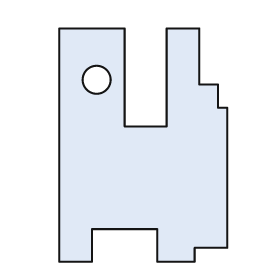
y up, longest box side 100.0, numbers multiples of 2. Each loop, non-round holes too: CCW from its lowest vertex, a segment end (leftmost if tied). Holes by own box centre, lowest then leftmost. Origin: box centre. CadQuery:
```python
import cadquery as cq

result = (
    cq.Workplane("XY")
    .moveTo(-36.0, -50.0)
    .lineTo(-22.0, -50.0)
    .lineTo(-22.0, -36.0)
    .lineTo(6.0, -36.0)
    .lineTo(6.0, -50.0)
    .lineTo(22.0, -50.0)
    .lineTo(22.0, -44.0)
    .lineTo(36.0, -44.0)
    .lineTo(36.0, 16.0)
    .lineTo(32.0, 16.0)
    .lineTo(32.0, 26.0)
    .lineTo(24.0, 26.0)
    .lineTo(24.0, 50.0)
    .lineTo(10.0, 50.0)
    .lineTo(10.0, 8.0)
    .lineTo(-8.0, 8.0)
    .lineTo(-8.0, 50.0)
    .lineTo(-36.0, 50.0)
    .close()
    .moveTo(-20.0, 28.0)
    .circle(6.0)
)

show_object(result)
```